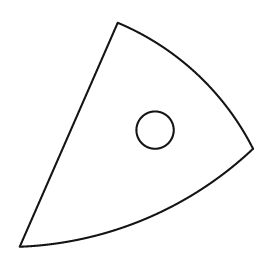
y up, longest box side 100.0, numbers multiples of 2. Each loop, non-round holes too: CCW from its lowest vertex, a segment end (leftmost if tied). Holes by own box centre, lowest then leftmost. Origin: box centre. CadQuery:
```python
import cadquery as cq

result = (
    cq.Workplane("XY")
    .moveTo(-50.0, -48.0)
    .threePointArc((4.0, -36.0), (50.0, -6.0))
    .threePointArc((26.0, 26.0), (-8.0, 48.0))
    .close()
    .moveTo(8.0, 2.0)
    .circle(8.0)
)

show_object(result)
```